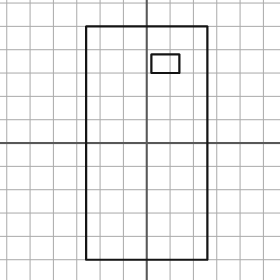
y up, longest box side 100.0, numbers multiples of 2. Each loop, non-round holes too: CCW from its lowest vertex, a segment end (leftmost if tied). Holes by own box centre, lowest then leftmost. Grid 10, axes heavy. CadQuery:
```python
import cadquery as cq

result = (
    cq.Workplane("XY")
    .moveTo(-26.0, -50.0)
    .lineTo(26.0, -50.0)
    .lineTo(26.0, 50.0)
    .lineTo(-26.0, 50.0)
    .close()
    .moveTo(2.0, 30.0)
    .lineTo(14.0, 30.0)
    .lineTo(14.0, 38.0)
    .lineTo(2.0, 38.0)
    .close()
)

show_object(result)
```